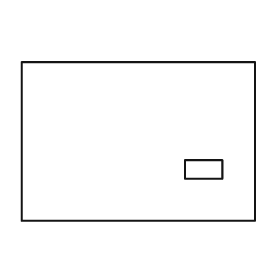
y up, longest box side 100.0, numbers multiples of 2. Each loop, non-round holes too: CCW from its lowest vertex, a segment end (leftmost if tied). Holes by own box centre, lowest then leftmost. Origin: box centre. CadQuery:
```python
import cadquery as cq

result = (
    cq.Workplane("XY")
    .moveTo(-50.0, -34.0)
    .lineTo(50.0, -34.0)
    .lineTo(50.0, 34.0)
    .lineTo(-50.0, 34.0)
    .close()
    .moveTo(20.0, -16.0)
    .lineTo(36.0, -16.0)
    .lineTo(36.0, -8.0)
    .lineTo(20.0, -8.0)
    .close()
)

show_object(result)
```